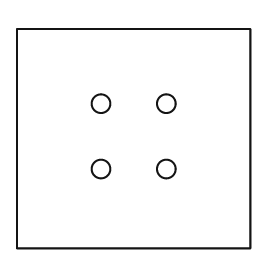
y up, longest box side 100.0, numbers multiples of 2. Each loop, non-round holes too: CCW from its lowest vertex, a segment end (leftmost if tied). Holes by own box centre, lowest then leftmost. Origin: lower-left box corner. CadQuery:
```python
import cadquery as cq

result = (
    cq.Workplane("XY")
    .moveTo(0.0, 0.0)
    .lineTo(100.0, 0.0)
    .lineTo(100.0, 94.0)
    .lineTo(0.0, 94.0)
    .close()
    .moveTo(36.0, 34.0)
    .circle(4.0)
    .moveTo(64.0, 34.0)
    .circle(4.0)
    .moveTo(36.0, 62.0)
    .circle(4.0)
    .moveTo(64.0, 62.0)
    .circle(4.0)
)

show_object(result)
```